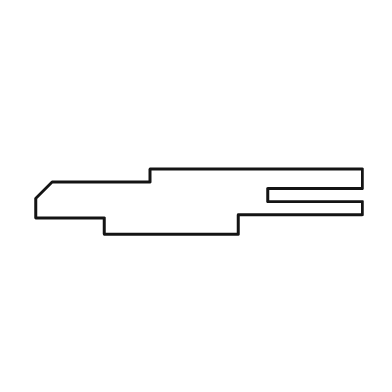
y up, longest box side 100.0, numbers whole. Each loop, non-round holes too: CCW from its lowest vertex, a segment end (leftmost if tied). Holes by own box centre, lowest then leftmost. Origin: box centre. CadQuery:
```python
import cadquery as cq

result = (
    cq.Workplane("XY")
    .moveTo(-29.0, -10.0)
    .lineTo(12.0, -10.0)
    .lineTo(12.0, -4.0)
    .lineTo(50.0, -4.0)
    .lineTo(50.0, 0.0)
    .lineTo(21.0, 0.0)
    .lineTo(21.0, 4.0)
    .lineTo(50.0, 4.0)
    .lineTo(50.0, 10.0)
    .lineTo(-15.0, 10.0)
    .lineTo(-15.0, 6.0)
    .lineTo(-45.0, 6.0)
    .lineTo(-50.0, 1.0)
    .lineTo(-50.0, -5.0)
    .lineTo(-29.0, -5.0)
    .close()
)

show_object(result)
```